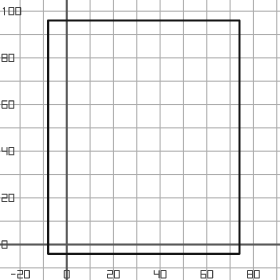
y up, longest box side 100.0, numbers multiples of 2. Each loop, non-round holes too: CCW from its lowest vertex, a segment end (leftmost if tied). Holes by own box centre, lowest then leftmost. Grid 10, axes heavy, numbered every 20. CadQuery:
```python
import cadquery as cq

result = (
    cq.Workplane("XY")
    .moveTo(-8.0, -4.0)
    .lineTo(74.0, -4.0)
    .lineTo(74.0, 96.0)
    .lineTo(-8.0, 96.0)
    .close()
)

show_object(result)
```